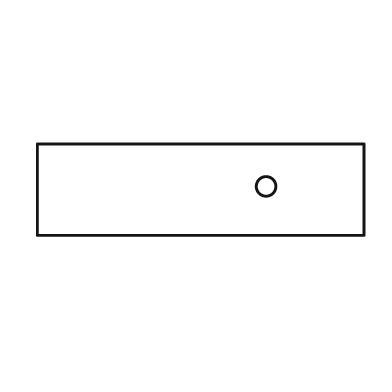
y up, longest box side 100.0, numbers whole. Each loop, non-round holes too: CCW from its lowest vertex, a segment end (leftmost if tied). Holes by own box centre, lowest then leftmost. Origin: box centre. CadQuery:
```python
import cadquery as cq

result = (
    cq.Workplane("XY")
    .moveTo(-50.0, -14.0)
    .lineTo(50.0, -14.0)
    .lineTo(50.0, 14.0)
    .lineTo(-50.0, 14.0)
    .close()
    .moveTo(20.0, 1.0)
    .circle(3.0)
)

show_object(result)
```